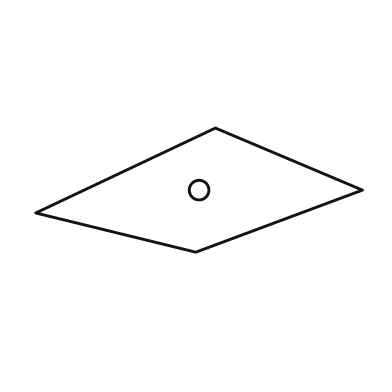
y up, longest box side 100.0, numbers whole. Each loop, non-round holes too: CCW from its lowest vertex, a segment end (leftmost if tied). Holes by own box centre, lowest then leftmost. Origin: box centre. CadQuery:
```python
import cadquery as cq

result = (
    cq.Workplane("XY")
    .moveTo(-1.0, -19.0)
    .lineTo(50.0, 0.0)
    .lineTo(5.0, 19.0)
    .lineTo(-50.0, -7.0)
    .close()
    .moveTo(0.0, 0.0)
    .circle(3.0)
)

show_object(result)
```